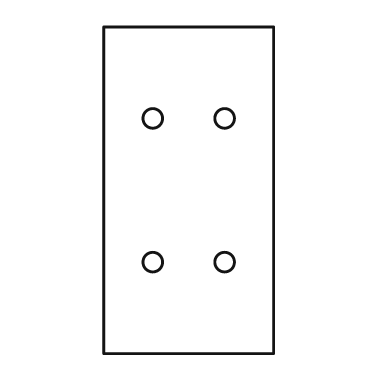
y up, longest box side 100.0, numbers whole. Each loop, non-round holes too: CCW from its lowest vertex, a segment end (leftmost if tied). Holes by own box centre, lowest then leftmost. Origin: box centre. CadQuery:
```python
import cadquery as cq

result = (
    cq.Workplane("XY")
    .moveTo(-26.0, -50.0)
    .lineTo(26.0, -50.0)
    .lineTo(26.0, 50.0)
    .lineTo(-26.0, 50.0)
    .close()
    .moveTo(-11.0, -22.0)
    .circle(3.0)
    .moveTo(11.0, -22.0)
    .circle(3.0)
    .moveTo(-11.0, 22.0)
    .circle(3.0)
    .moveTo(11.0, 22.0)
    .circle(3.0)
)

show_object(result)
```